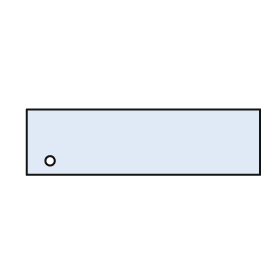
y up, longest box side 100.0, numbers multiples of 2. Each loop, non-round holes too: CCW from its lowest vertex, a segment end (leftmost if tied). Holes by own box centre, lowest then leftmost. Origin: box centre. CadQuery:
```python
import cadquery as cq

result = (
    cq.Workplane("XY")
    .moveTo(-50.0, -14.0)
    .lineTo(50.0, -14.0)
    .lineTo(50.0, 14.0)
    .lineTo(-50.0, 14.0)
    .close()
    .moveTo(-40.0, -8.0)
    .circle(2.0)
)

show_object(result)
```